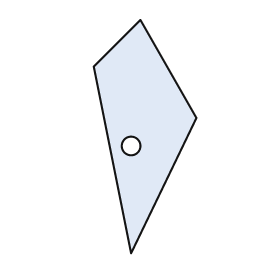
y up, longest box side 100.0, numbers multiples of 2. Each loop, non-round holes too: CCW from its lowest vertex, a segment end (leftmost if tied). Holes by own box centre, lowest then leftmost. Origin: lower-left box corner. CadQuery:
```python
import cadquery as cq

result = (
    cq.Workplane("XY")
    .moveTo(16.0, 0.0)
    .lineTo(44.0, 58.0)
    .lineTo(20.0, 100.0)
    .lineTo(0.0, 80.0)
    .close()
    .moveTo(16.0, 46.0)
    .circle(4.0)
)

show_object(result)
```